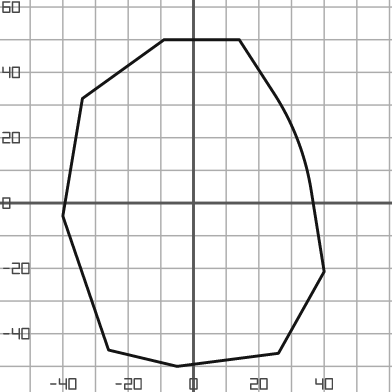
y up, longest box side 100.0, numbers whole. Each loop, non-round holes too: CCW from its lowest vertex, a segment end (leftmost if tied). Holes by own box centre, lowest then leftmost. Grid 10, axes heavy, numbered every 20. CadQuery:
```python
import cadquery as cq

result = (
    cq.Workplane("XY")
    .moveTo(-5.0, -50.0)
    .lineTo(26.0, -46.0)
    .lineTo(40.0, -21.0)
    .lineTo(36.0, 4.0)
    .threePointArc((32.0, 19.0), (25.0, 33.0))
    .lineTo(14.0, 50.0)
    .lineTo(-9.0, 50.0)
    .lineTo(-34.0, 32.0)
    .lineTo(-40.0, -4.0)
    .lineTo(-26.0, -45.0)
    .close()
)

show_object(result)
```